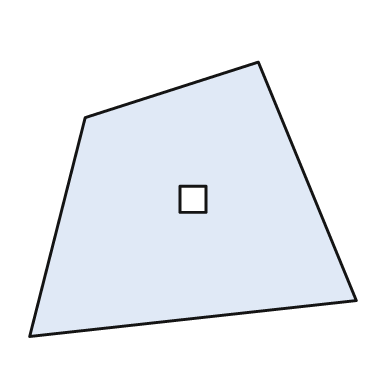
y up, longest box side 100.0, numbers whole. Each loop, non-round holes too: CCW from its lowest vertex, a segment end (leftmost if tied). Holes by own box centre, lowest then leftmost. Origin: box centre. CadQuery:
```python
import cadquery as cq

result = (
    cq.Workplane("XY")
    .moveTo(-50.0, -42.0)
    .lineTo(50.0, -31.0)
    .lineTo(20.0, 42.0)
    .lineTo(-33.0, 25.0)
    .close()
    .moveTo(-4.0, -4.0)
    .lineTo(4.0, -4.0)
    .lineTo(4.0, 4.0)
    .lineTo(-4.0, 4.0)
    .close()
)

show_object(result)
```